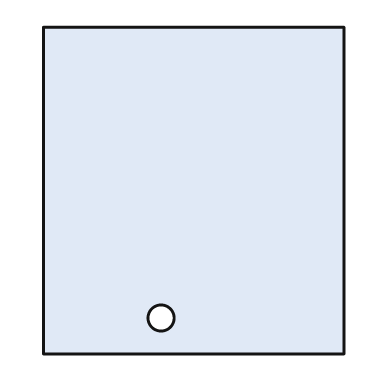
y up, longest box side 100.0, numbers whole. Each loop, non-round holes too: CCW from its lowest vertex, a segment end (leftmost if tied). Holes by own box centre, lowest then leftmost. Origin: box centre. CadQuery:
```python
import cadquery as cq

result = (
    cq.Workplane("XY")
    .moveTo(-46.0, -50.0)
    .lineTo(46.0, -50.0)
    .lineTo(46.0, 50.0)
    .lineTo(-46.0, 50.0)
    .close()
    .moveTo(-10.0, -39.0)
    .circle(4.0)
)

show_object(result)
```